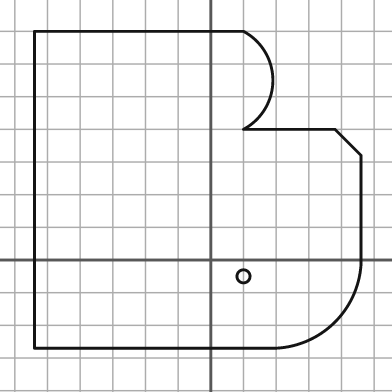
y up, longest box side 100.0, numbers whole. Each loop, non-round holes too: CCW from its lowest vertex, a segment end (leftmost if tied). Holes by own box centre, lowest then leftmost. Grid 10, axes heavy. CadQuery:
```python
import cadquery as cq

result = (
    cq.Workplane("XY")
    .moveTo(-54.0, -27.0)
    .lineTo(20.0, -27.0)
    .threePointArc((38.0, -19.0), (46.0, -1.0))
    .lineTo(46.0, 32.0)
    .lineTo(38.0, 40.0)
    .lineTo(10.0, 40.0)
    .threePointArc((19.0, 55.0), (10.0, 70.0))
    .lineTo(-54.0, 70.0)
    .close()
    .moveTo(10.0, -5.0)
    .circle(2.0)
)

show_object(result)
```